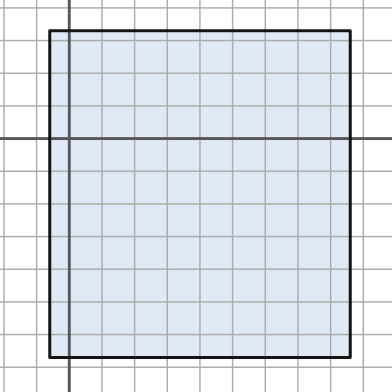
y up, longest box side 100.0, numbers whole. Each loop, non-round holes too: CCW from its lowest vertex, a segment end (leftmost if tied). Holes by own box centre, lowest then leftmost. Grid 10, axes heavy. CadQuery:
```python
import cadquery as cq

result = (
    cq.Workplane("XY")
    .moveTo(-6.0, -67.0)
    .lineTo(86.0, -67.0)
    .lineTo(86.0, 33.0)
    .lineTo(-6.0, 33.0)
    .close()
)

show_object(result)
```